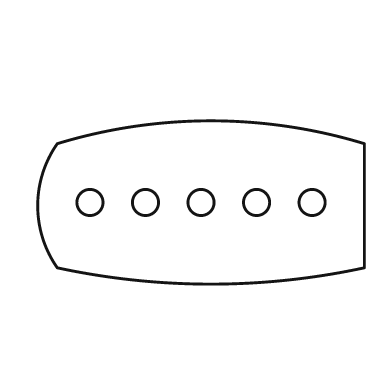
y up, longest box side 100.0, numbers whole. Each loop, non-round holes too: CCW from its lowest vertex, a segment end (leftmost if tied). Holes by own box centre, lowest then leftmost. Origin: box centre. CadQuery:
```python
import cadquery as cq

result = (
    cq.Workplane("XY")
    .moveTo(-44.0, -20.0)
    .threePointArc((3.0, -25.0), (50.0, -20.0))
    .lineTo(50.0, 18.0)
    .threePointArc((3.0, 25.0), (-44.0, 18.0))
    .threePointArc((-50.0, -1.0), (-44.0, -20.0))
    .close()
    .moveTo(-34.0, 0.0)
    .circle(4.0)
    .moveTo(-17.0, 0.0)
    .circle(4.0)
    .moveTo(0.0, 0.0)
    .circle(4.0)
    .moveTo(17.0, 0.0)
    .circle(4.0)
    .moveTo(34.0, 0.0)
    .circle(4.0)
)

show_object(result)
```